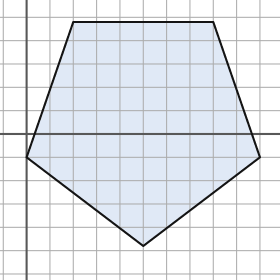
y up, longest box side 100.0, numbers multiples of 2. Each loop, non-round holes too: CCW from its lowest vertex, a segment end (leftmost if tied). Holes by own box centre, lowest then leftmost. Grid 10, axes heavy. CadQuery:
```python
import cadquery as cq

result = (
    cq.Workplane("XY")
    .moveTo(50.0, -48.0)
    .lineTo(100.0, -10.0)
    .lineTo(80.0, 48.0)
    .lineTo(20.0, 48.0)
    .lineTo(0.0, -10.0)
    .close()
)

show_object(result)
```